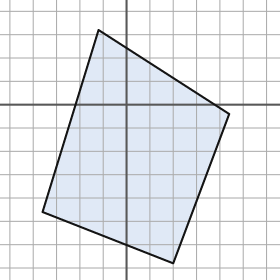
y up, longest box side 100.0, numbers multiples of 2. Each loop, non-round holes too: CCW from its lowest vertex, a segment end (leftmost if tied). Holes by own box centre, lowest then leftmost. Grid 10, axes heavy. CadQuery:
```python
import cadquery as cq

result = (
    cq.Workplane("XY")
    .moveTo(20.0, -68.0)
    .lineTo(44.0, -4.0)
    .lineTo(-12.0, 32.0)
    .lineTo(-36.0, -46.0)
    .close()
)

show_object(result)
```